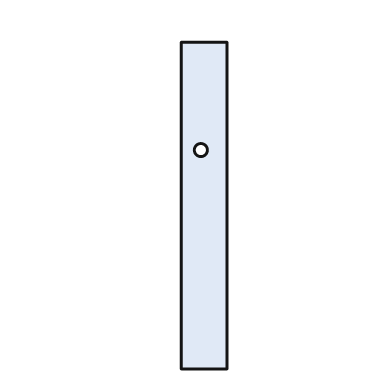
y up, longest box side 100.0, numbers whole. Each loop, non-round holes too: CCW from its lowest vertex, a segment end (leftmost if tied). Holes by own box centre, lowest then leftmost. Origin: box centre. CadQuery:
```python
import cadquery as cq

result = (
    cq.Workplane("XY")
    .moveTo(-7.0, -50.0)
    .lineTo(7.0, -50.0)
    .lineTo(7.0, 50.0)
    .lineTo(-7.0, 50.0)
    .close()
    .moveTo(-1.0, 17.0)
    .circle(2.0)
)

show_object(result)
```